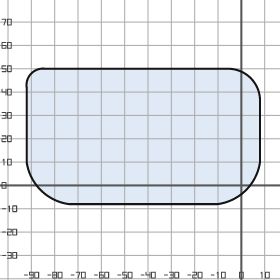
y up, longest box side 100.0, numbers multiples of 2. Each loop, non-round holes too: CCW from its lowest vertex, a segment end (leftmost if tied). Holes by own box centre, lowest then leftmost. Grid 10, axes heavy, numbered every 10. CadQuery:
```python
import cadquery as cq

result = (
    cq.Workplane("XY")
    .moveTo(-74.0, -8.0)
    .lineTo(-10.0, -8.0)
    .threePointArc((2.0, -2.0), (8.0, 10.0))
    .lineTo(8.0, 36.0)
    .threePointArc((4.0, 46.0), (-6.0, 50.0))
    .lineTo(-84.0, 50.0)
    .threePointArc((-90.0, 48.0), (-92.0, 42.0))
    .lineTo(-92.0, 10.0)
    .threePointArc((-86.0, -2.0), (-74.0, -8.0))
    .close()
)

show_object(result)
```